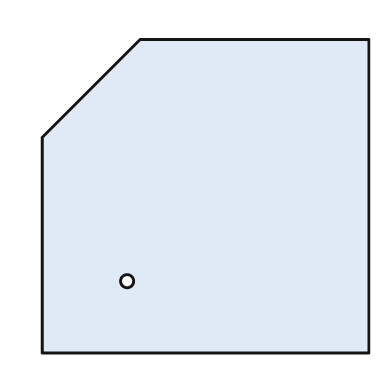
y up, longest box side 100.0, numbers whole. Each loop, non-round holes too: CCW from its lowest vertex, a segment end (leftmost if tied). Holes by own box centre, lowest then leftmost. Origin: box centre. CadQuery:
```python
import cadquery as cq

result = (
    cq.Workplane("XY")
    .moveTo(-50.0, -48.0)
    .lineTo(50.0, -48.0)
    .lineTo(50.0, 48.0)
    .lineTo(-20.0, 48.0)
    .lineTo(-50.0, 18.0)
    .close()
    .moveTo(-24.0, -26.0)
    .circle(2.0)
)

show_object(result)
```